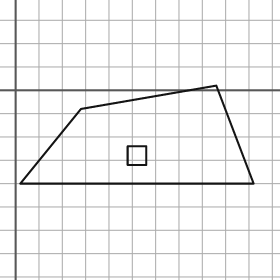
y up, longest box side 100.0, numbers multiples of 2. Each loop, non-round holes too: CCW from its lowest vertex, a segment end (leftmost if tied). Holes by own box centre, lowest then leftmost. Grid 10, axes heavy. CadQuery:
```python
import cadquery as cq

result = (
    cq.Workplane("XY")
    .moveTo(2.0, -40.0)
    .lineTo(102.0, -40.0)
    .lineTo(86.0, 2.0)
    .lineTo(28.0, -8.0)
    .close()
    .moveTo(48.0, -32.0)
    .lineTo(56.0, -32.0)
    .lineTo(56.0, -24.0)
    .lineTo(48.0, -24.0)
    .close()
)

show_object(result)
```